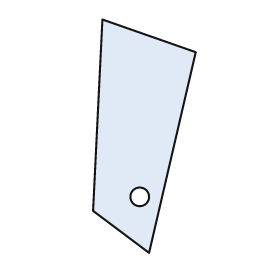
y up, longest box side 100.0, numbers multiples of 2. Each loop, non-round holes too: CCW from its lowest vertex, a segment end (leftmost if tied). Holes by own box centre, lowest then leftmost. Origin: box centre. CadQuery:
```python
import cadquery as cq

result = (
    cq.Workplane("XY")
    .moveTo(2.0, -50.0)
    .lineTo(22.0, 36.0)
    .lineTo(-18.0, 50.0)
    .lineTo(-22.0, -32.0)
    .close()
    .moveTo(-2.0, -26.0)
    .circle(4.0)
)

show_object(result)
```